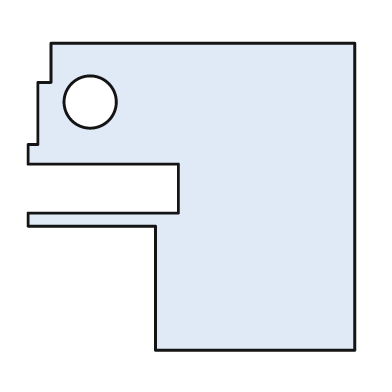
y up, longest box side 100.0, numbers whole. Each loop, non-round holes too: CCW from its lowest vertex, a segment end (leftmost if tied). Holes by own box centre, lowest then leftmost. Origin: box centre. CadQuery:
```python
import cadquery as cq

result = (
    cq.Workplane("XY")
    .moveTo(-11.0, -47.0)
    .lineTo(50.0, -47.0)
    .lineTo(50.0, 47.0)
    .lineTo(-43.0, 47.0)
    .lineTo(-43.0, 35.0)
    .lineTo(-47.0, 35.0)
    .lineTo(-47.0, 16.0)
    .lineTo(-50.0, 16.0)
    .lineTo(-50.0, 10.0)
    .lineTo(-4.0, 10.0)
    .lineTo(-4.0, -5.0)
    .lineTo(-50.0, -5.0)
    .lineTo(-50.0, -9.0)
    .lineTo(-11.0, -9.0)
    .close()
    .moveTo(-31.0, 29.0)
    .circle(8.0)
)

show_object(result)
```